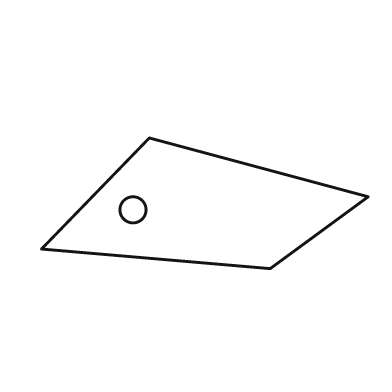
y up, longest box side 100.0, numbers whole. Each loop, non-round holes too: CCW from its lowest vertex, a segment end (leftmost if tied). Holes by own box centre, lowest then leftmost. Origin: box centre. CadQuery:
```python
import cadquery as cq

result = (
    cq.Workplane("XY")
    .moveTo(20.0, -20.0)
    .lineTo(50.0, 2.0)
    .lineTo(-17.0, 20.0)
    .lineTo(-50.0, -14.0)
    .close()
    .moveTo(-22.0, -2.0)
    .circle(4.0)
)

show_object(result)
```